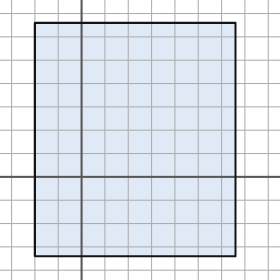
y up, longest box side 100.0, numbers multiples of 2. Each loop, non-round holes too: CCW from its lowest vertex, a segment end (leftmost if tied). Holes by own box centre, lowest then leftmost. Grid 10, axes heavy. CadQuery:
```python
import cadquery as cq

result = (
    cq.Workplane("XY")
    .moveTo(-20.0, -34.0)
    .lineTo(66.0, -34.0)
    .lineTo(66.0, 66.0)
    .lineTo(-20.0, 66.0)
    .close()
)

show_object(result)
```